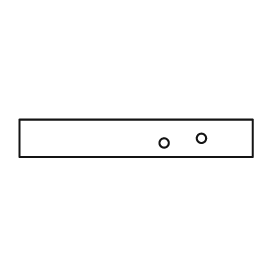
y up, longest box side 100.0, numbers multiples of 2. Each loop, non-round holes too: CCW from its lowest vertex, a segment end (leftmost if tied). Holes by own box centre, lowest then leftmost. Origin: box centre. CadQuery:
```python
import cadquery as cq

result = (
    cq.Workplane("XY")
    .moveTo(-50.0, -8.0)
    .lineTo(50.0, -8.0)
    .lineTo(50.0, 8.0)
    .lineTo(-50.0, 8.0)
    .close()
    .moveTo(12.0, -2.0)
    .circle(2.0)
    .moveTo(28.0, 0.0)
    .circle(2.0)
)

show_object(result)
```